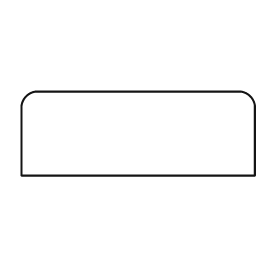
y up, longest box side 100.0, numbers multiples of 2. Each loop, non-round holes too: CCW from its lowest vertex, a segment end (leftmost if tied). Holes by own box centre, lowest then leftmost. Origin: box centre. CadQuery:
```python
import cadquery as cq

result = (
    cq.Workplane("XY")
    .moveTo(-50.0, -18.0)
    .lineTo(50.0, -18.0)
    .lineTo(50.0, 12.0)
    .threePointArc((48.0, 16.0), (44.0, 18.0))
    .lineTo(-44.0, 18.0)
    .threePointArc((-48.0, 16.0), (-50.0, 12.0))
    .close()
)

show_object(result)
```